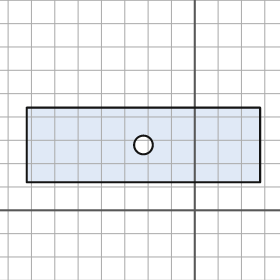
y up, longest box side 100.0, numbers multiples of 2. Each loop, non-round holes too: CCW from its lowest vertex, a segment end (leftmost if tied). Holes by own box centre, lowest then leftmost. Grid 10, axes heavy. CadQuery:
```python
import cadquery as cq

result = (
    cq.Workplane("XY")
    .moveTo(-72.0, 12.0)
    .lineTo(28.0, 12.0)
    .lineTo(28.0, 44.0)
    .lineTo(-72.0, 44.0)
    .close()
    .moveTo(-22.0, 28.0)
    .circle(4.0)
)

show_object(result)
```